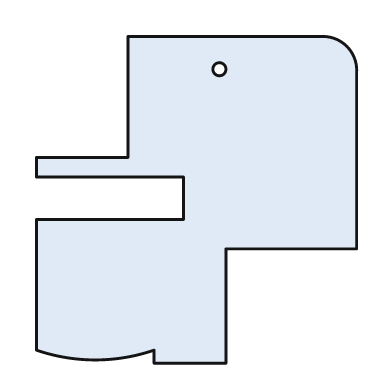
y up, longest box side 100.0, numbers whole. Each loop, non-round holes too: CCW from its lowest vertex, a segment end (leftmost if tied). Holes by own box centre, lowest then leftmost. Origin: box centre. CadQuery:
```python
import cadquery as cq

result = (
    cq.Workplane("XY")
    .moveTo(-13.0, -50.0)
    .lineTo(9.0, -50.0)
    .lineTo(9.0, -15.0)
    .lineTo(49.0, -15.0)
    .lineTo(49.0, 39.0)
    .threePointArc((46.0, 47.0), (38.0, 50.0))
    .lineTo(-21.0, 50.0)
    .lineTo(-21.0, 13.0)
    .lineTo(-49.0, 13.0)
    .lineTo(-49.0, 7.0)
    .lineTo(-4.0, 7.0)
    .lineTo(-4.0, -6.0)
    .lineTo(-49.0, -6.0)
    .lineTo(-49.0, -46.0)
    .threePointArc((-31.0, -49.0), (-13.0, -46.0))
    .close()
    .moveTo(7.0, 40.0)
    .circle(2.0)
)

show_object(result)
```